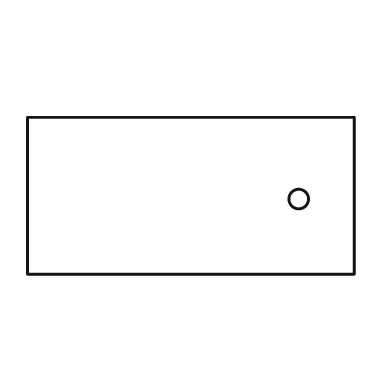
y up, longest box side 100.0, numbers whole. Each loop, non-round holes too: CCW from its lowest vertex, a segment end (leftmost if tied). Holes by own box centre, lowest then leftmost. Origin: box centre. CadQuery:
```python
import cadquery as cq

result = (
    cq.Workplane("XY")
    .moveTo(-50.0, -24.0)
    .lineTo(50.0, -24.0)
    .lineTo(50.0, 24.0)
    .lineTo(-50.0, 24.0)
    .close()
    .moveTo(33.0, -1.0)
    .circle(3.0)
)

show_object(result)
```